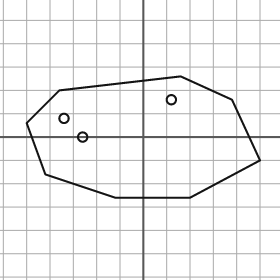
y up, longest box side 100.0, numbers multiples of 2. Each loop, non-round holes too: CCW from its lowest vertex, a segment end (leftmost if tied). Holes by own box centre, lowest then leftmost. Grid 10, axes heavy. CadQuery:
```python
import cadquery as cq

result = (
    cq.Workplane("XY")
    .moveTo(-12.0, -26.0)
    .lineTo(20.0, -26.0)
    .lineTo(50.0, -10.0)
    .lineTo(38.0, 16.0)
    .lineTo(16.0, 26.0)
    .lineTo(-36.0, 20.0)
    .lineTo(-50.0, 6.0)
    .lineTo(-42.0, -16.0)
    .close()
    .moveTo(-26.0, 0.0)
    .circle(2.0)
    .moveTo(-34.0, 8.0)
    .circle(2.0)
    .moveTo(12.0, 16.0)
    .circle(2.0)
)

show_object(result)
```